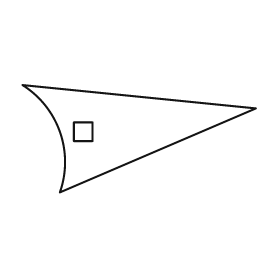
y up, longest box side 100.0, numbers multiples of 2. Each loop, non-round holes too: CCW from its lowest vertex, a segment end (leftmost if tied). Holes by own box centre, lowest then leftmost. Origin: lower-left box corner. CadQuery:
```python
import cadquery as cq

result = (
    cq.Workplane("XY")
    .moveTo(16.0, 0.0)
    .lineTo(100.0, 36.0)
    .lineTo(0.0, 46.0)
    .threePointArc((16.0, 26.0), (16.0, 0.0))
    .close()
    .moveTo(22.0, 22.0)
    .lineTo(30.0, 22.0)
    .lineTo(30.0, 30.0)
    .lineTo(22.0, 30.0)
    .close()
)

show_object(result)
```